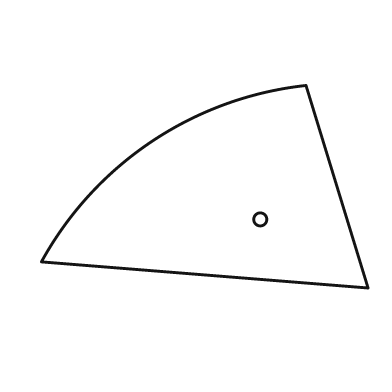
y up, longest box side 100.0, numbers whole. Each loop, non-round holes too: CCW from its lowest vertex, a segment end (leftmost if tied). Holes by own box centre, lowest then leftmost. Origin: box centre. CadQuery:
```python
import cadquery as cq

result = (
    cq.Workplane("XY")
    .moveTo(50.0, -31.0)
    .lineTo(31.0, 31.0)
    .threePointArc((-16.0, 14.0), (-50.0, -23.0))
    .close()
    .moveTo(17.0, -10.0)
    .circle(2.0)
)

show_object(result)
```